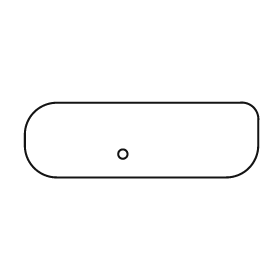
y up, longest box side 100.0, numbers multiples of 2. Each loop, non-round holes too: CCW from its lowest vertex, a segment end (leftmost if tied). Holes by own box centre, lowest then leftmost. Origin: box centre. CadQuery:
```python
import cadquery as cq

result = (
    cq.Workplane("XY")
    .moveTo(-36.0, -16.0)
    .lineTo(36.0, -16.0)
    .threePointArc((46.0, -12.0), (50.0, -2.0))
    .lineTo(50.0, 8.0)
    .threePointArc((48.0, 14.0), (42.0, 16.0))
    .lineTo(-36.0, 16.0)
    .threePointArc((-46.0, 12.0), (-50.0, 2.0))
    .lineTo(-50.0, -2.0)
    .threePointArc((-46.0, -12.0), (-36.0, -16.0))
    .close()
    .moveTo(-8.0, -6.0)
    .circle(2.0)
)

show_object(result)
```